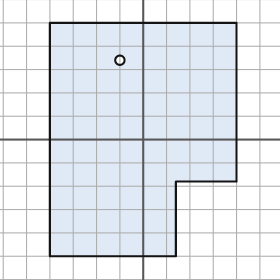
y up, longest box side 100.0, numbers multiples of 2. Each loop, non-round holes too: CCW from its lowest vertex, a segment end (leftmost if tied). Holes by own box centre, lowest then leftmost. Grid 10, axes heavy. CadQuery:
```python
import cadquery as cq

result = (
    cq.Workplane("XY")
    .moveTo(-40.0, -50.0)
    .lineTo(14.0, -50.0)
    .lineTo(14.0, -18.0)
    .lineTo(40.0, -18.0)
    .lineTo(40.0, 50.0)
    .lineTo(-40.0, 50.0)
    .close()
    .moveTo(-10.0, 34.0)
    .circle(2.0)
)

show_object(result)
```